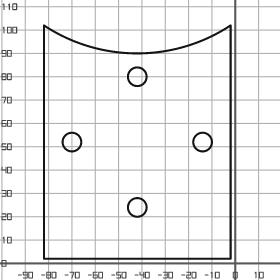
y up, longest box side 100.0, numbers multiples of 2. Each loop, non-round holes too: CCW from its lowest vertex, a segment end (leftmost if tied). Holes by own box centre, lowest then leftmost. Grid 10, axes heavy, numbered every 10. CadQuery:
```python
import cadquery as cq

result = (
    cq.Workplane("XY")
    .moveTo(-82.0, 2.0)
    .lineTo(-2.0, 2.0)
    .lineTo(-2.0, 102.0)
    .threePointArc((-42.0, 90.0), (-82.0, 102.0))
    .close()
    .moveTo(-42.0, 24.0)
    .circle(4.0)
    .moveTo(-70.0, 52.0)
    .circle(4.0)
    .moveTo(-14.0, 52.0)
    .circle(4.0)
    .moveTo(-42.0, 80.0)
    .circle(4.0)
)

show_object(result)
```